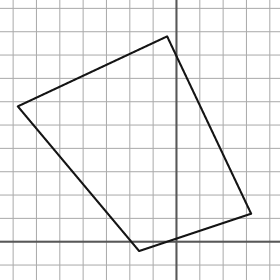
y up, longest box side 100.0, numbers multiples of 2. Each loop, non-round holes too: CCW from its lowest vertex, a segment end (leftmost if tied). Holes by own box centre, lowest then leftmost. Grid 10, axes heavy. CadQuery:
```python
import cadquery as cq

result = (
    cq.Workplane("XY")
    .moveTo(-16.0, -4.0)
    .lineTo(32.0, 12.0)
    .lineTo(-4.0, 88.0)
    .lineTo(-68.0, 58.0)
    .close()
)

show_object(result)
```